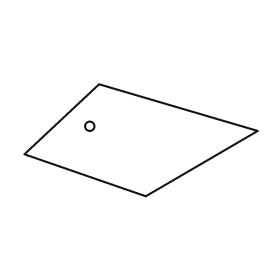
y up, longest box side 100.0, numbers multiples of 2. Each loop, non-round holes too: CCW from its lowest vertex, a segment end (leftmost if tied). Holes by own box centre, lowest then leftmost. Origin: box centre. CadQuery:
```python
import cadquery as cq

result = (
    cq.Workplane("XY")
    .moveTo(2.0, -24.0)
    .lineTo(50.0, 4.0)
    .lineTo(-18.0, 24.0)
    .lineTo(-50.0, -6.0)
    .close()
    .moveTo(-22.0, 6.0)
    .circle(2.0)
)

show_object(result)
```